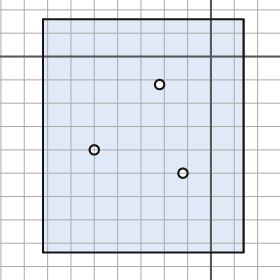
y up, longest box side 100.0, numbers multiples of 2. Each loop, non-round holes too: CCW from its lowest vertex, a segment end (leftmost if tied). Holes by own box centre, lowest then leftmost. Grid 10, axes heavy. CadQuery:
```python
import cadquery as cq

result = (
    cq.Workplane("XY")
    .moveTo(-72.0, -84.0)
    .lineTo(14.0, -84.0)
    .lineTo(14.0, 16.0)
    .lineTo(-72.0, 16.0)
    .close()
    .moveTo(-12.0, -50.0)
    .circle(2.0)
    .moveTo(-50.0, -40.0)
    .circle(2.0)
    .moveTo(-22.0, -12.0)
    .circle(2.0)
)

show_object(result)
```